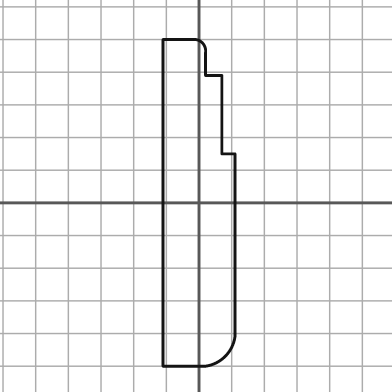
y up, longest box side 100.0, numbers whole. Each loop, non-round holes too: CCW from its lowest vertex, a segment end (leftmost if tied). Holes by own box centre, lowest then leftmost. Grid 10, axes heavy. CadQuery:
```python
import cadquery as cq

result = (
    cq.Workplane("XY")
    .moveTo(-11.0, -50.0)
    .lineTo(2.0, -50.0)
    .threePointArc((8.0, -47.0), (11.0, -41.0))
    .lineTo(11.0, 15.0)
    .lineTo(7.0, 15.0)
    .lineTo(7.0, 39.0)
    .lineTo(2.0, 39.0)
    .lineTo(2.0, 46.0)
    .threePointArc((1.0, 49.0), (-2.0, 50.0))
    .lineTo(-11.0, 50.0)
    .close()
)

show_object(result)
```